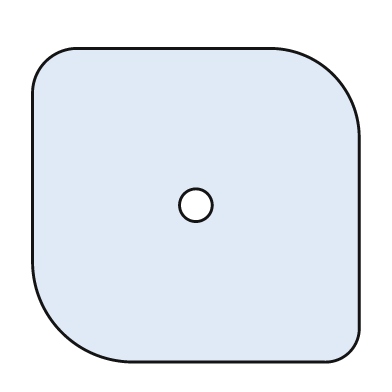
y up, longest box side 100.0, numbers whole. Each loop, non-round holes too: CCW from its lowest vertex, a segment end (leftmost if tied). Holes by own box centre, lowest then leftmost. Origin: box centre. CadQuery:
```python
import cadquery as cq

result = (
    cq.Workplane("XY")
    .moveTo(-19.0, -48.0)
    .lineTo(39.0, -48.0)
    .threePointArc((47.0, -45.0), (50.0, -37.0))
    .lineTo(50.0, 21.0)
    .threePointArc((42.0, 40.0), (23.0, 48.0))
    .lineTo(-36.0, 48.0)
    .threePointArc((-46.0, 44.0), (-50.0, 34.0))
    .lineTo(-50.0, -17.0)
    .threePointArc((-41.0, -39.0), (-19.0, -48.0))
    .close()
    .moveTo(0.0, 0.0)
    .circle(5.0)
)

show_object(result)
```